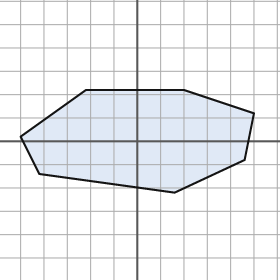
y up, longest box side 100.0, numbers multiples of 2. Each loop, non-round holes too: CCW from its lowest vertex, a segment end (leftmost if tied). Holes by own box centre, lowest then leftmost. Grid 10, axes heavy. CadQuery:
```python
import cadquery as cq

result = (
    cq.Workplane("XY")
    .moveTo(16.0, -22.0)
    .lineTo(46.0, -8.0)
    .lineTo(50.0, 12.0)
    .lineTo(20.0, 22.0)
    .lineTo(-22.0, 22.0)
    .lineTo(-50.0, 2.0)
    .lineTo(-42.0, -14.0)
    .close()
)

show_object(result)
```